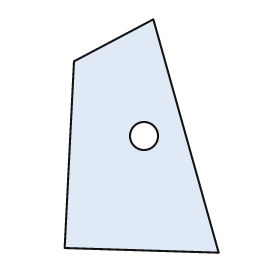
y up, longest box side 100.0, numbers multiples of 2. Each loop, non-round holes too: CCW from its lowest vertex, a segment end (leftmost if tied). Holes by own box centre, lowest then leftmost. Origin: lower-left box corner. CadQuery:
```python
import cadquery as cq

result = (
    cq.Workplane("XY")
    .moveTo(66.0, 0.0)
    .lineTo(38.0, 100.0)
    .lineTo(4.0, 82.0)
    .lineTo(0.0, 2.0)
    .close()
    .moveTo(34.0, 50.0)
    .circle(6.0)
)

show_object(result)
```